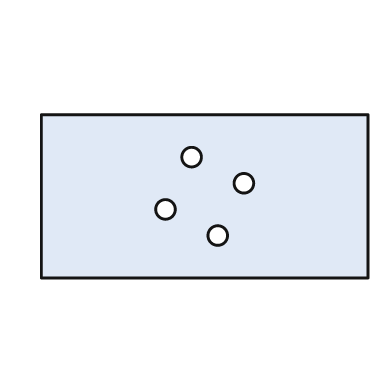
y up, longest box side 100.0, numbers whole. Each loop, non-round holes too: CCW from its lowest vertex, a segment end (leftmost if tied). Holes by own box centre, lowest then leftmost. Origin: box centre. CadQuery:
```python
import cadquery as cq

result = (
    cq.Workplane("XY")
    .moveTo(-50.0, -25.0)
    .lineTo(50.0, -25.0)
    .lineTo(50.0, 25.0)
    .lineTo(-50.0, 25.0)
    .close()
    .moveTo(4.0, -12.0)
    .circle(3.0)
    .moveTo(-12.0, -4.0)
    .circle(3.0)
    .moveTo(12.0, 4.0)
    .circle(3.0)
    .moveTo(-4.0, 12.0)
    .circle(3.0)
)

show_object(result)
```